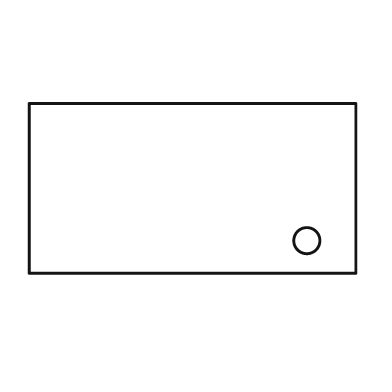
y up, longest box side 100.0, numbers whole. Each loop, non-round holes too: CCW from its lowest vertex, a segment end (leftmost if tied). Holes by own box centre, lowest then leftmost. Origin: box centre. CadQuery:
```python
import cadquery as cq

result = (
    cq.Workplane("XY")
    .moveTo(-50.0, -26.0)
    .lineTo(50.0, -26.0)
    .lineTo(50.0, 26.0)
    .lineTo(-50.0, 26.0)
    .close()
    .moveTo(35.0, -16.0)
    .circle(4.0)
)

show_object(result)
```